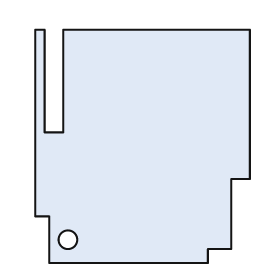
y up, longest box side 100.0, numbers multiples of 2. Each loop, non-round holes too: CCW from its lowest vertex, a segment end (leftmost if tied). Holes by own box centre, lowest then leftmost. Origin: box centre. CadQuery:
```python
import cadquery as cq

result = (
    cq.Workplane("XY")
    .moveTo(-40.0, -50.0)
    .lineTo(28.0, -50.0)
    .lineTo(28.0, -44.0)
    .lineTo(38.0, -44.0)
    .lineTo(38.0, -14.0)
    .lineTo(46.0, -14.0)
    .lineTo(46.0, 50.0)
    .lineTo(-34.0, 50.0)
    .lineTo(-34.0, 6.0)
    .lineTo(-42.0, 6.0)
    .lineTo(-42.0, 50.0)
    .lineTo(-46.0, 50.0)
    .lineTo(-46.0, -30.0)
    .lineTo(-40.0, -30.0)
    .close()
    .moveTo(-32.0, -40.0)
    .circle(4.0)
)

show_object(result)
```